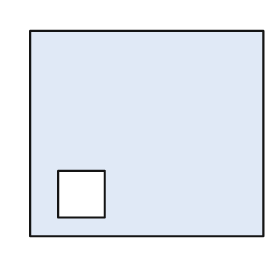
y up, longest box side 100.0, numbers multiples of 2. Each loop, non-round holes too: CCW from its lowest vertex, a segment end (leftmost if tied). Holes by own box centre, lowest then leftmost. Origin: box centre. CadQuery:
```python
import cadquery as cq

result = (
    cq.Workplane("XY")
    .moveTo(-50.0, -44.0)
    .lineTo(50.0, -44.0)
    .lineTo(50.0, 44.0)
    .lineTo(-50.0, 44.0)
    .close()
    .moveTo(-38.0, -36.0)
    .lineTo(-18.0, -36.0)
    .lineTo(-18.0, -16.0)
    .lineTo(-38.0, -16.0)
    .close()
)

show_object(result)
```